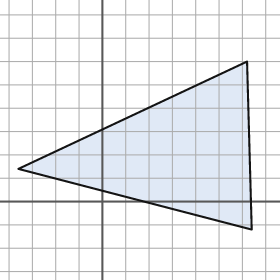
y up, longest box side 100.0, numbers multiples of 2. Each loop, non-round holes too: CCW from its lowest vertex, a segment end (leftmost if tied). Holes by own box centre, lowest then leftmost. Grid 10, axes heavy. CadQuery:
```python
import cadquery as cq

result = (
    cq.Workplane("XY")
    .moveTo(64.0, -12.0)
    .lineTo(62.0, 60.0)
    .lineTo(-36.0, 14.0)
    .close()
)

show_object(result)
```